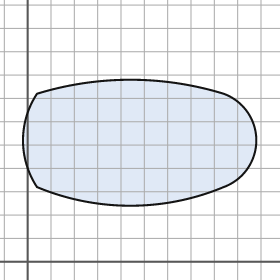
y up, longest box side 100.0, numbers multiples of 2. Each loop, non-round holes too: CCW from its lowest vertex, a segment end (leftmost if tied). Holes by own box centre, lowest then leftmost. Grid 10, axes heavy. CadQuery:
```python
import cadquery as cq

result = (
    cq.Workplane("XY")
    .moveTo(4.0, 32.0)
    .threePointArc((44.0, 24.0), (84.0, 32.0))
    .threePointArc((98.0, 52.0), (84.0, 72.0))
    .threePointArc((44.0, 78.0), (4.0, 72.0))
    .threePointArc((-2.0, 52.0), (4.0, 32.0))
    .close()
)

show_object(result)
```